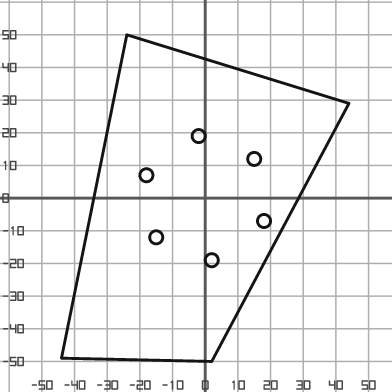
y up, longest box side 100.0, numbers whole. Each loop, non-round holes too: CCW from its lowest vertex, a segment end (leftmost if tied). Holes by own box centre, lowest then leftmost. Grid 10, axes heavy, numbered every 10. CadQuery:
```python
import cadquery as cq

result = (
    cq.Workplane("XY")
    .moveTo(2.0, -50.0)
    .lineTo(44.0, 29.0)
    .lineTo(-24.0, 50.0)
    .lineTo(-44.0, -49.0)
    .close()
    .moveTo(2.0, -19.0)
    .circle(2.0)
    .moveTo(-15.0, -12.0)
    .circle(2.0)
    .moveTo(18.0, -7.0)
    .circle(2.0)
    .moveTo(-18.0, 7.0)
    .circle(2.0)
    .moveTo(15.0, 12.0)
    .circle(2.0)
    .moveTo(-2.0, 19.0)
    .circle(2.0)
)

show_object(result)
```